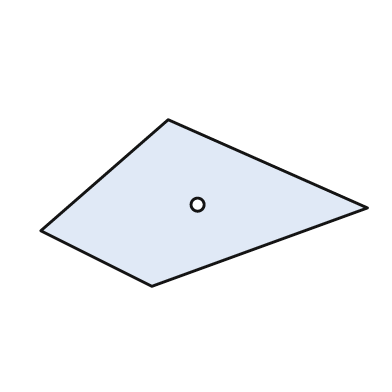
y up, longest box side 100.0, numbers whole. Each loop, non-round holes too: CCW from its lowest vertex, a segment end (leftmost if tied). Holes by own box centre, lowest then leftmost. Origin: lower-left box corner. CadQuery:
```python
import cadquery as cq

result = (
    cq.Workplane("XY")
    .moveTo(34.0, 0.0)
    .lineTo(100.0, 24.0)
    .lineTo(39.0, 51.0)
    .lineTo(0.0, 17.0)
    .close()
    .moveTo(48.0, 25.0)
    .circle(2.0)
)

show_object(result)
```